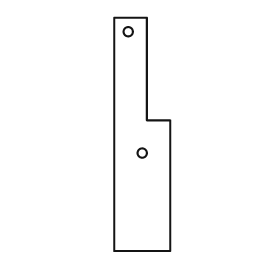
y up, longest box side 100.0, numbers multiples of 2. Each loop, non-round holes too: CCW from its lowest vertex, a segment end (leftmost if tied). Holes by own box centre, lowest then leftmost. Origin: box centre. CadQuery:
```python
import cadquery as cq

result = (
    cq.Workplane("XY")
    .moveTo(-12.0, -50.0)
    .lineTo(12.0, -50.0)
    .lineTo(12.0, 6.0)
    .lineTo(2.0, 6.0)
    .lineTo(2.0, 50.0)
    .lineTo(-12.0, 50.0)
    .close()
    .moveTo(0.0, -8.0)
    .circle(2.0)
    .moveTo(-6.0, 44.0)
    .circle(2.0)
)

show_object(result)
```